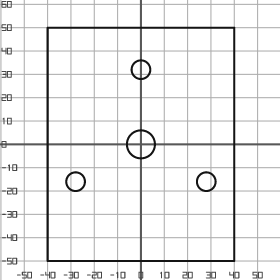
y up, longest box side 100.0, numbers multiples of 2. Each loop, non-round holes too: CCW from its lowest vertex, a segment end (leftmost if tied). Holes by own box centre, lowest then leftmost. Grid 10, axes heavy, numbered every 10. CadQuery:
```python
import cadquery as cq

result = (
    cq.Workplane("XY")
    .moveTo(-40.0, -50.0)
    .lineTo(40.0, -50.0)
    .lineTo(40.0, 50.0)
    .lineTo(-40.0, 50.0)
    .close()
    .moveTo(-28.0, -16.0)
    .circle(4.0)
    .moveTo(28.0, -16.0)
    .circle(4.0)
    .moveTo(0.0, 0.0)
    .circle(6.0)
    .moveTo(0.0, 32.0)
    .circle(4.0)
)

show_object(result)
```